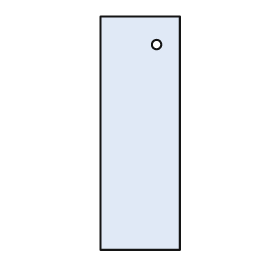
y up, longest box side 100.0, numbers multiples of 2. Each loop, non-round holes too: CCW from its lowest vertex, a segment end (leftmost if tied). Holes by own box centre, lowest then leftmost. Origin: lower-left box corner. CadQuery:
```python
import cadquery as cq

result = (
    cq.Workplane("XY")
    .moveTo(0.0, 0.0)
    .lineTo(34.0, 0.0)
    .lineTo(34.0, 100.0)
    .lineTo(0.0, 100.0)
    .close()
    .moveTo(24.0, 88.0)
    .circle(2.0)
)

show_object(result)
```